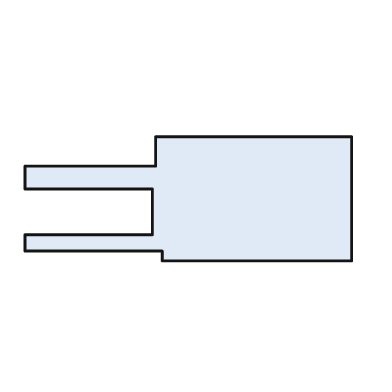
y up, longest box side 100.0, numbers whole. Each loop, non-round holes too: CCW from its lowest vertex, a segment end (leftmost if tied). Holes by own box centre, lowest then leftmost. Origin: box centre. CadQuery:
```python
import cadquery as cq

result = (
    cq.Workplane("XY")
    .moveTo(-8.0, -19.0)
    .lineTo(50.0, -19.0)
    .lineTo(50.0, 19.0)
    .lineTo(-10.0, 19.0)
    .lineTo(-10.0, 10.0)
    .lineTo(-50.0, 10.0)
    .lineTo(-50.0, 3.0)
    .lineTo(-11.0, 3.0)
    .lineTo(-11.0, -11.0)
    .lineTo(-50.0, -11.0)
    .lineTo(-50.0, -16.0)
    .lineTo(-8.0, -16.0)
    .close()
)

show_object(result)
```